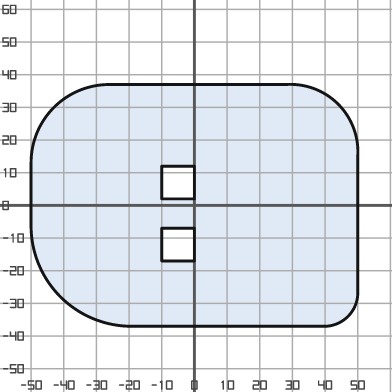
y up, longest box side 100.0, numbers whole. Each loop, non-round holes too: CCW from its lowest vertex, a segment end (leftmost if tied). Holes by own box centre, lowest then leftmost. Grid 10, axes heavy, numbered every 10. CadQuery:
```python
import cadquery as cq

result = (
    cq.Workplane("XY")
    .moveTo(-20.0, -37.0)
    .lineTo(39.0, -37.0)
    .threePointArc((47.0, -34.0), (50.0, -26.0))
    .lineTo(50.0, 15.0)
    .threePointArc((44.0, 31.0), (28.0, 37.0))
    .lineTo(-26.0, 37.0)
    .threePointArc((-43.0, 30.0), (-50.0, 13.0))
    .lineTo(-50.0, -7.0)
    .threePointArc((-41.0, -28.0), (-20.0, -37.0))
    .close()
    .moveTo(-10.0, -17.0)
    .lineTo(0.0, -17.0)
    .lineTo(0.0, -7.0)
    .lineTo(-10.0, -7.0)
    .close()
    .moveTo(-10.0, 2.0)
    .lineTo(0.0, 2.0)
    .lineTo(0.0, 12.0)
    .lineTo(-10.0, 12.0)
    .close()
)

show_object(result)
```